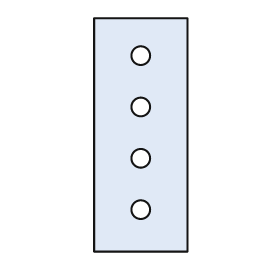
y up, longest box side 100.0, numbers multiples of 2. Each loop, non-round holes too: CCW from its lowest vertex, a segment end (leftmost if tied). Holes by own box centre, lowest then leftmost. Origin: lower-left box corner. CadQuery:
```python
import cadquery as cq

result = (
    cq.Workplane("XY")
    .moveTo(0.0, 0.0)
    .lineTo(40.0, 0.0)
    .lineTo(40.0, 100.0)
    .lineTo(0.0, 100.0)
    .close()
    .moveTo(20.0, 18.0)
    .circle(4.0)
    .moveTo(20.0, 40.0)
    .circle(4.0)
    .moveTo(20.0, 62.0)
    .circle(4.0)
    .moveTo(20.0, 84.0)
    .circle(4.0)
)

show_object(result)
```